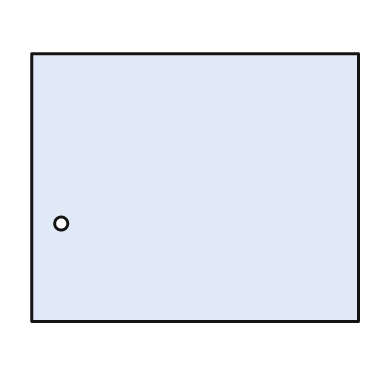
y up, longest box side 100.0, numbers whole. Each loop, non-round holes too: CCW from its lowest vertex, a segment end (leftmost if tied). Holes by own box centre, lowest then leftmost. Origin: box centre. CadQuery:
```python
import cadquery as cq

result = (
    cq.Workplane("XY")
    .moveTo(-50.0, -41.0)
    .lineTo(50.0, -41.0)
    .lineTo(50.0, 41.0)
    .lineTo(-50.0, 41.0)
    .close()
    .moveTo(-41.0, -11.0)
    .circle(2.0)
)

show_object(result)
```